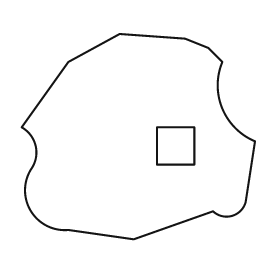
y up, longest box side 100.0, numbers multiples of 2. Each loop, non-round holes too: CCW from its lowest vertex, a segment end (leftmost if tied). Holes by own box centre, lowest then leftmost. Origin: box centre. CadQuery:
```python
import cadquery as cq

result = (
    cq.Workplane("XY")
    .moveTo(-2.0, -44.0)
    .lineTo(32.0, -32.0)
    .threePointArc((40.0, -34.0), (46.0, -28.0))
    .lineTo(50.0, -2.0)
    .threePointArc((36.0, 12.0), (36.0, 32.0))
    .lineTo(30.0, 38.0)
    .lineTo(20.0, 42.0)
    .lineTo(-8.0, 44.0)
    .lineTo(-30.0, 32.0)
    .lineTo(-50.0, 4.0)
    .threePointArc((-44.0, -4.0), (-46.0, -14.0))
    .threePointArc((-46.0, -32.0), (-30.0, -40.0))
    .close()
    .moveTo(8.0, -12.0)
    .lineTo(24.0, -12.0)
    .lineTo(24.0, 4.0)
    .lineTo(8.0, 4.0)
    .close()
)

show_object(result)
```